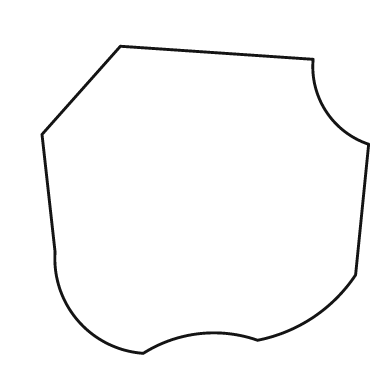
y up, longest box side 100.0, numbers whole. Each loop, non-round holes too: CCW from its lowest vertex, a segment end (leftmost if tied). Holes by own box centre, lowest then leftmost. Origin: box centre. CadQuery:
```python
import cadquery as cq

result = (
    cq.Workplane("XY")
    .moveTo(-19.0, -47.0)
    .threePointArc((-2.0, -41.0), (16.0, -43.0))
    .threePointArc((33.0, -36.0), (46.0, -23.0))
    .lineTo(50.0, 17.0)
    .threePointArc((37.0, 27.0), (33.0, 43.0))
    .lineTo(-26.0, 47.0)
    .lineTo(-50.0, 20.0)
    .lineTo(-46.0, -16.0)
    .threePointArc((-39.0, -37.0), (-19.0, -47.0))
    .close()
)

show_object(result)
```